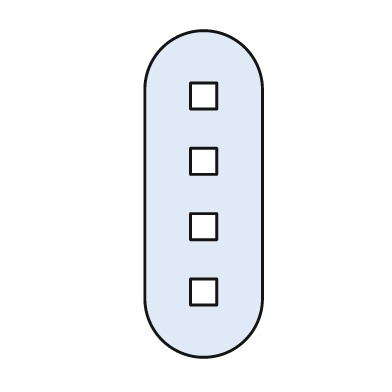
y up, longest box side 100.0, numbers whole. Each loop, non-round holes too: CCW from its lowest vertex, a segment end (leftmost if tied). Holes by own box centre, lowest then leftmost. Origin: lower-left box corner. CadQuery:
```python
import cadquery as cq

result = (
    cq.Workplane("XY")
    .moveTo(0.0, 18.0)
    .threePointArc((18.0, 0.0), (36.0, 18.0))
    .lineTo(36.0, 82.0)
    .threePointArc((18.0, 100.0), (0.0, 82.0))
    .close()
    .moveTo(14.0, 16.0)
    .lineTo(22.0, 16.0)
    .lineTo(22.0, 24.0)
    .lineTo(14.0, 24.0)
    .close()
    .moveTo(14.0, 36.0)
    .lineTo(22.0, 36.0)
    .lineTo(22.0, 44.0)
    .lineTo(14.0, 44.0)
    .close()
    .moveTo(14.0, 56.0)
    .lineTo(22.0, 56.0)
    .lineTo(22.0, 64.0)
    .lineTo(14.0, 64.0)
    .close()
    .moveTo(14.0, 76.0)
    .lineTo(22.0, 76.0)
    .lineTo(22.0, 84.0)
    .lineTo(14.0, 84.0)
    .close()
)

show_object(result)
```